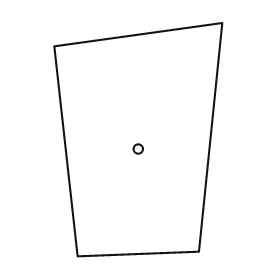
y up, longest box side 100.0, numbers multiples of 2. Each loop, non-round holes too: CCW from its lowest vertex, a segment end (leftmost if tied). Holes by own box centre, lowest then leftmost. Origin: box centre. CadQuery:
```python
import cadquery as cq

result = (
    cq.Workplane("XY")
    .moveTo(-26.0, -50.0)
    .lineTo(26.0, -48.0)
    .lineTo(36.0, 50.0)
    .lineTo(-36.0, 40.0)
    .close()
    .moveTo(0.0, -4.0)
    .circle(2.0)
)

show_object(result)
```